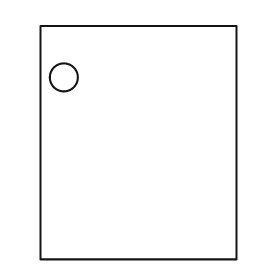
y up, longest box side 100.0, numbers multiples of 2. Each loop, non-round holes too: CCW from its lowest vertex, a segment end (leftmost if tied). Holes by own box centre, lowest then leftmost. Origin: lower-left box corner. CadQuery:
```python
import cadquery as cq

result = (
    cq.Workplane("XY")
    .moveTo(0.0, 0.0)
    .lineTo(84.0, 0.0)
    .lineTo(84.0, 100.0)
    .lineTo(0.0, 100.0)
    .close()
    .moveTo(10.0, 78.0)
    .circle(6.0)
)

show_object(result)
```